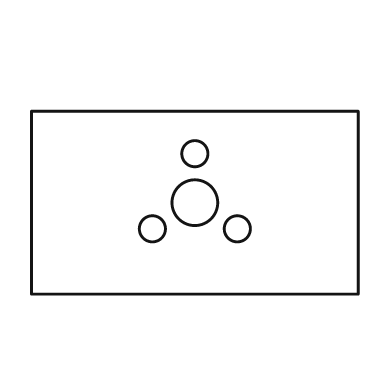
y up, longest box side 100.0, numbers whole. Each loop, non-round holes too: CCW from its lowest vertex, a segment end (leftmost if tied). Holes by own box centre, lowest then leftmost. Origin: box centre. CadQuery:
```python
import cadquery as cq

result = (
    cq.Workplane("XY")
    .moveTo(-50.0, -28.0)
    .lineTo(50.0, -28.0)
    .lineTo(50.0, 28.0)
    .lineTo(-50.0, 28.0)
    .close()
    .moveTo(-13.0, -8.0)
    .circle(4.0)
    .moveTo(13.0, -8.0)
    .circle(4.0)
    .moveTo(0.0, 0.0)
    .circle(7.0)
    .moveTo(0.0, 15.0)
    .circle(4.0)
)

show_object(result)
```